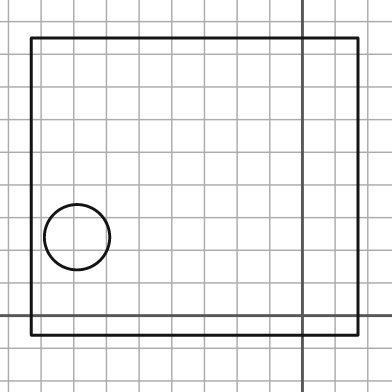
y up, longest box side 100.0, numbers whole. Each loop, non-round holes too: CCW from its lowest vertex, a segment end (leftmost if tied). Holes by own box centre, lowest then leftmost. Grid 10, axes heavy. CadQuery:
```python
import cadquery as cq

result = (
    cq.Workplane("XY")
    .moveTo(-83.0, -6.0)
    .lineTo(17.0, -6.0)
    .lineTo(17.0, 85.0)
    .lineTo(-83.0, 85.0)
    .close()
    .moveTo(-69.0, 24.0)
    .circle(10.0)
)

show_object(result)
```